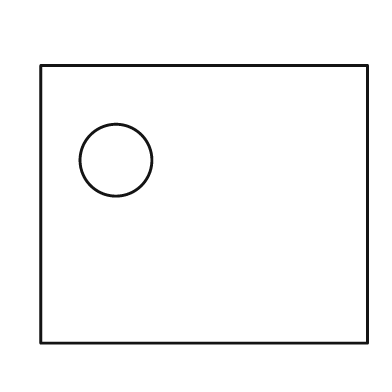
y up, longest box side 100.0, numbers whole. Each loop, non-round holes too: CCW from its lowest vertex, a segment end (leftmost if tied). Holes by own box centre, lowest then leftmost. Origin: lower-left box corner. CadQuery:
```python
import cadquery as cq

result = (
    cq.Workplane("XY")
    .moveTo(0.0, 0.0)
    .lineTo(100.0, 0.0)
    .lineTo(100.0, 85.0)
    .lineTo(0.0, 85.0)
    .close()
    .moveTo(23.0, 56.0)
    .circle(11.0)
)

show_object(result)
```